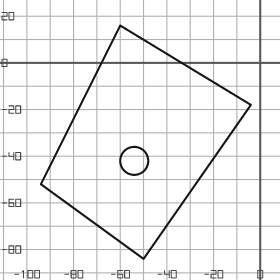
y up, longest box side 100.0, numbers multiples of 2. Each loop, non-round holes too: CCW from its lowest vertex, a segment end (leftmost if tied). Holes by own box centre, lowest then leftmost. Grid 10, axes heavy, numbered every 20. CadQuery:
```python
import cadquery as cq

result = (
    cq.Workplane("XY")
    .moveTo(-50.0, -84.0)
    .lineTo(-4.0, -18.0)
    .lineTo(-60.0, 16.0)
    .lineTo(-94.0, -52.0)
    .close()
    .moveTo(-54.0, -42.0)
    .circle(6.0)
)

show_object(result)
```